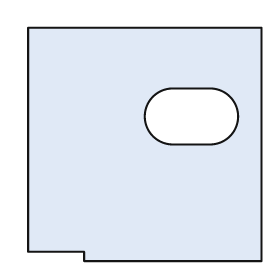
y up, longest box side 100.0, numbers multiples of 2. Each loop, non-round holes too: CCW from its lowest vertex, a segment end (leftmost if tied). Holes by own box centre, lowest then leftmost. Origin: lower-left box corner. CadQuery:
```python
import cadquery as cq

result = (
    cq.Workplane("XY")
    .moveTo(24.0, 0.0)
    .lineTo(100.0, 0.0)
    .lineTo(100.0, 100.0)
    .lineTo(0.0, 100.0)
    .lineTo(0.0, 4.0)
    .lineTo(24.0, 4.0)
    .close()
    .moveTo(62.0, 50.0)
    .lineTo(78.0, 50.0)
    .threePointArc((90.0, 62.0), (78.0, 74.0))
    .lineTo(62.0, 74.0)
    .threePointArc((50.0, 62.0), (62.0, 50.0))
    .close()
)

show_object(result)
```